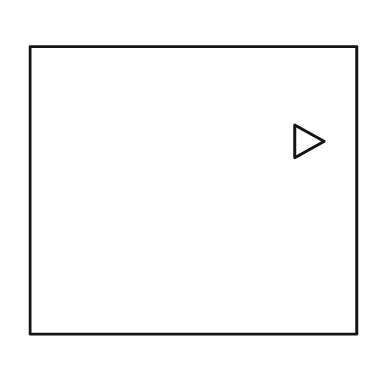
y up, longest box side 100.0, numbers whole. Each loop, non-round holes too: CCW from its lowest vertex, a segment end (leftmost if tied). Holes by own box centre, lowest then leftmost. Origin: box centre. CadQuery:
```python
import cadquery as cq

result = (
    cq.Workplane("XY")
    .moveTo(-50.0, -44.0)
    .lineTo(50.0, -44.0)
    .lineTo(50.0, 44.0)
    .lineTo(-50.0, 44.0)
    .close()
    .moveTo(31.0, 10.0)
    .lineTo(40.0, 15.0)
    .lineTo(31.0, 20.0)
    .close()
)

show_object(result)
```